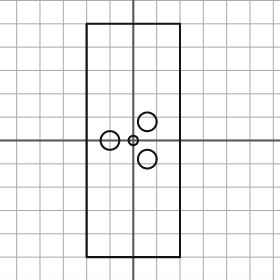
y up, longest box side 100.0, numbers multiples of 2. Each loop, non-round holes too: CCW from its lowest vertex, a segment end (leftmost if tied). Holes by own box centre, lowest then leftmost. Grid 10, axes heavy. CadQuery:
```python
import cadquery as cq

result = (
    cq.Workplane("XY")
    .moveTo(-20.0, -50.0)
    .lineTo(20.0, -50.0)
    .lineTo(20.0, 50.0)
    .lineTo(-20.0, 50.0)
    .close()
    .moveTo(6.0, -8.0)
    .circle(4.0)
    .moveTo(-10.0, 0.0)
    .circle(4.0)
    .moveTo(0.0, 0.0)
    .circle(2.0)
    .moveTo(6.0, 8.0)
    .circle(4.0)
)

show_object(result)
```